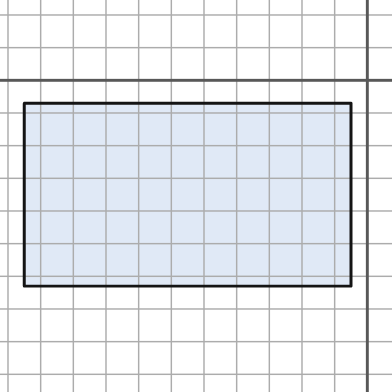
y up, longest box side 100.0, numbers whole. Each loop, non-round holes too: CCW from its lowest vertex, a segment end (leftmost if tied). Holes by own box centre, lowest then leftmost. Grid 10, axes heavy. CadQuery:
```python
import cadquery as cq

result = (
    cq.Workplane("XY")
    .moveTo(-105.0, -63.0)
    .lineTo(-5.0, -63.0)
    .lineTo(-5.0, -7.0)
    .lineTo(-105.0, -7.0)
    .close()
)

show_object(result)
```